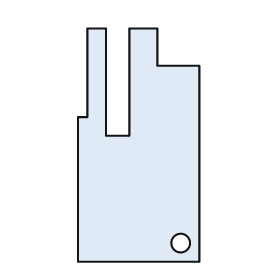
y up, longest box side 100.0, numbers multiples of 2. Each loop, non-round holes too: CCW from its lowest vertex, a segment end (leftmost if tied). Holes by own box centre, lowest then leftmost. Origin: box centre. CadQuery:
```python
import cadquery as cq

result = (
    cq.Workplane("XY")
    .moveTo(-26.0, -50.0)
    .lineTo(26.0, -50.0)
    .lineTo(26.0, 34.0)
    .lineTo(8.0, 34.0)
    .lineTo(8.0, 50.0)
    .lineTo(-4.0, 50.0)
    .lineTo(-4.0, 4.0)
    .lineTo(-14.0, 4.0)
    .lineTo(-14.0, 50.0)
    .lineTo(-22.0, 50.0)
    .lineTo(-22.0, 12.0)
    .lineTo(-26.0, 12.0)
    .close()
    .moveTo(18.0, -42.0)
    .circle(4.0)
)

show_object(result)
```